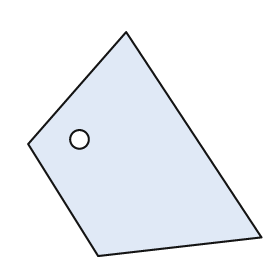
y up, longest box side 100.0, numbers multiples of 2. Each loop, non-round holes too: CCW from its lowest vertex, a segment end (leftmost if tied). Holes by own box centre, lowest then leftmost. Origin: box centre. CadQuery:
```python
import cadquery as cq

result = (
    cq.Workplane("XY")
    .moveTo(-20.0, -48.0)
    .lineTo(50.0, -40.0)
    .lineTo(-8.0, 48.0)
    .lineTo(-50.0, 0.0)
    .close()
    .moveTo(-28.0, 2.0)
    .circle(4.0)
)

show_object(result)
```